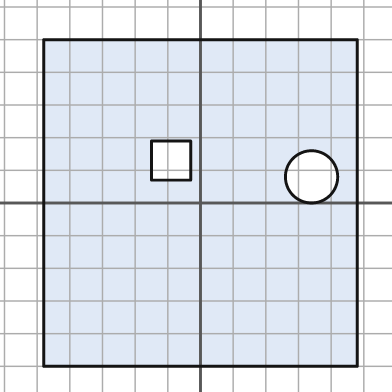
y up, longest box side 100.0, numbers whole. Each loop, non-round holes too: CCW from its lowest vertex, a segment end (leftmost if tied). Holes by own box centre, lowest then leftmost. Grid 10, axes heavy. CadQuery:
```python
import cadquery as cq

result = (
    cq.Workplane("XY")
    .moveTo(-48.0, -50.0)
    .lineTo(48.0, -50.0)
    .lineTo(48.0, 50.0)
    .lineTo(-48.0, 50.0)
    .close()
    .moveTo(34.0, 8.0)
    .circle(8.0)
    .moveTo(-15.0, 7.0)
    .lineTo(-3.0, 7.0)
    .lineTo(-3.0, 19.0)
    .lineTo(-15.0, 19.0)
    .close()
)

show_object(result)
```